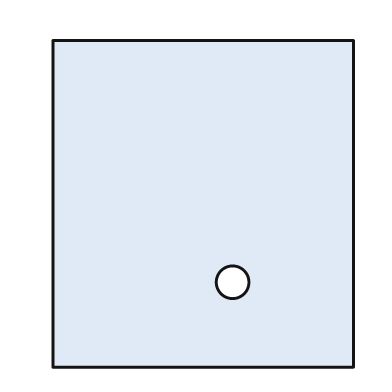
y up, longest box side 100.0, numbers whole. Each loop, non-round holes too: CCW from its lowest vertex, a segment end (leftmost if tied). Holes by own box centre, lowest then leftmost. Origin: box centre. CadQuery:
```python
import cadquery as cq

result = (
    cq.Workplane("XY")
    .moveTo(-46.0, -50.0)
    .lineTo(46.0, -50.0)
    .lineTo(46.0, 50.0)
    .lineTo(-46.0, 50.0)
    .close()
    .moveTo(9.0, -24.0)
    .circle(5.0)
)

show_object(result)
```